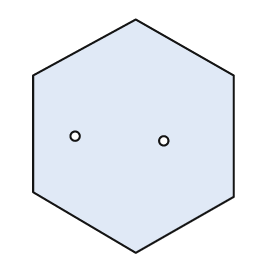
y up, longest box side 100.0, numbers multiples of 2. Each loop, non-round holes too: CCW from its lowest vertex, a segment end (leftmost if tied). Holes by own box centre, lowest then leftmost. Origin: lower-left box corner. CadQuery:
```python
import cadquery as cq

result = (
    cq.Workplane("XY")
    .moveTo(44.0, 0.0)
    .lineTo(86.0, 24.0)
    .lineTo(86.0, 76.0)
    .lineTo(44.0, 100.0)
    .lineTo(0.0, 76.0)
    .lineTo(0.0, 26.0)
    .close()
    .moveTo(56.0, 48.0)
    .circle(2.0)
    .moveTo(18.0, 50.0)
    .circle(2.0)
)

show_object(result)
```